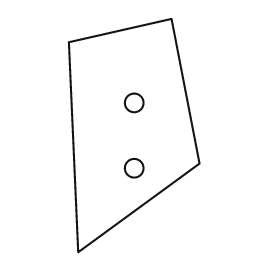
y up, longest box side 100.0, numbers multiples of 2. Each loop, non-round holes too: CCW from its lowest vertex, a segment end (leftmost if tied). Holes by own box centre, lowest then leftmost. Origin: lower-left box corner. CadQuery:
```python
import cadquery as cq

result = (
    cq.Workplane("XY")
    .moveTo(4.0, 0.0)
    .lineTo(56.0, 38.0)
    .lineTo(44.0, 100.0)
    .lineTo(0.0, 90.0)
    .close()
    .moveTo(28.0, 36.0)
    .circle(4.0)
    .moveTo(28.0, 64.0)
    .circle(4.0)
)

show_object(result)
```